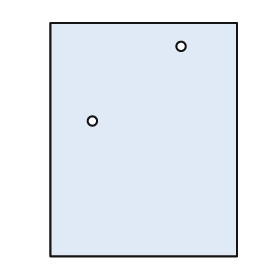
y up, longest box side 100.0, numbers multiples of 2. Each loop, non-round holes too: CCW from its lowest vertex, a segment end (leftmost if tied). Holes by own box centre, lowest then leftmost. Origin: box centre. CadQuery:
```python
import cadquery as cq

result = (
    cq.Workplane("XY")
    .moveTo(-40.0, -50.0)
    .lineTo(40.0, -50.0)
    .lineTo(40.0, 50.0)
    .lineTo(-40.0, 50.0)
    .close()
    .moveTo(-22.0, 8.0)
    .circle(2.0)
    .moveTo(16.0, 40.0)
    .circle(2.0)
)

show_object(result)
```